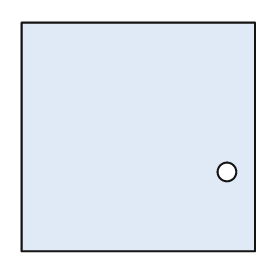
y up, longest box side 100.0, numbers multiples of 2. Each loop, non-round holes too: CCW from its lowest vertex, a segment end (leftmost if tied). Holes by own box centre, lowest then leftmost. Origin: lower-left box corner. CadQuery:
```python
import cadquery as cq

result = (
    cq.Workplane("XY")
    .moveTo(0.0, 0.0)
    .lineTo(100.0, 0.0)
    .lineTo(100.0, 98.0)
    .lineTo(0.0, 98.0)
    .close()
    .moveTo(88.0, 34.0)
    .circle(4.0)
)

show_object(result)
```